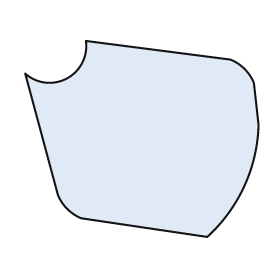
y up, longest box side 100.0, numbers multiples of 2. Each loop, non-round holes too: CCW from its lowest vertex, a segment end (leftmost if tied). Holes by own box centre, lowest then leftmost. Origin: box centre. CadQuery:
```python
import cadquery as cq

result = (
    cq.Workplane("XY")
    .moveTo(28.0, -42.0)
    .threePointArc((44.0, -20.0), (50.0, 6.0))
    .lineTo(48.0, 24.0)
    .threePointArc((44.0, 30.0), (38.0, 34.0))
    .lineTo(-24.0, 42.0)
    .threePointArc((-32.0, 26.0), (-50.0, 28.0))
    .lineTo(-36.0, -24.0)
    .threePointArc((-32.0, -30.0), (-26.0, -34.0))
    .close()
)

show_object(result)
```